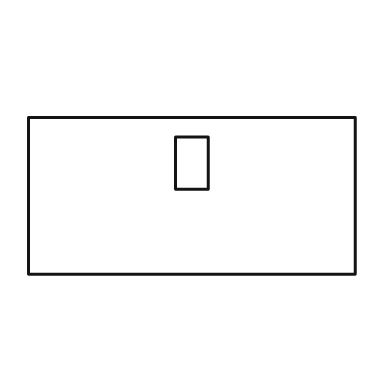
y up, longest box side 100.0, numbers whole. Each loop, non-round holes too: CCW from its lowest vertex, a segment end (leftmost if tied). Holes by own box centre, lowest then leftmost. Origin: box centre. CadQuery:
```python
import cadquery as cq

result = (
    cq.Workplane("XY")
    .moveTo(-50.0, -24.0)
    .lineTo(50.0, -24.0)
    .lineTo(50.0, 24.0)
    .lineTo(-50.0, 24.0)
    .close()
    .moveTo(-5.0, 2.0)
    .lineTo(5.0, 2.0)
    .lineTo(5.0, 18.0)
    .lineTo(-5.0, 18.0)
    .close()
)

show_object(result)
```